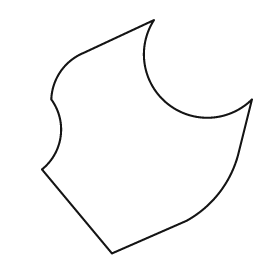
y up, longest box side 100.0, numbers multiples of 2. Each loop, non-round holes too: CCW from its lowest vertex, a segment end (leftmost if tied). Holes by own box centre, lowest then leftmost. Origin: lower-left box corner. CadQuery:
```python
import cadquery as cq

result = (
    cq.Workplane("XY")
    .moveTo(30.0, 0.0)
    .lineTo(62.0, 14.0)
    .threePointArc((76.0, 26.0), (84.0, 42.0))
    .lineTo(90.0, 66.0)
    .threePointArc((54.0, 64.0), (48.0, 100.0))
    .lineTo(18.0, 86.0)
    .threePointArc((8.0, 78.0), (4.0, 66.0))
    .threePointArc((8.0, 50.0), (0.0, 36.0))
    .close()
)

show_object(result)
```